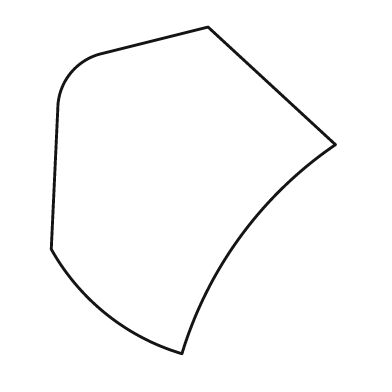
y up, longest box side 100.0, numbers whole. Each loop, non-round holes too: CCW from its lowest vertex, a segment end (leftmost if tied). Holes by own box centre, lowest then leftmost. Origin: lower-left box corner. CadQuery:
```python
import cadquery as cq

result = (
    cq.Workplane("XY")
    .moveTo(40.0, 0.0)
    .threePointArc((58.0, 36.0), (87.0, 64.0))
    .lineTo(48.0, 100.0)
    .lineTo(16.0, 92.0)
    .threePointArc((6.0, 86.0), (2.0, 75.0))
    .lineTo(0.0, 32.0)
    .threePointArc((17.0, 12.0), (40.0, 0.0))
    .close()
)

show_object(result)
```